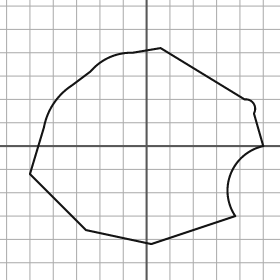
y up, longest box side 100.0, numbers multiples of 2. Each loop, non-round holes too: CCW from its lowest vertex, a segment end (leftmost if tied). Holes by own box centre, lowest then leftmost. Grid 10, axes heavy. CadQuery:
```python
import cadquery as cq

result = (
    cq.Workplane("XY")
    .moveTo(2.0, -42.0)
    .lineTo(38.0, -30.0)
    .threePointArc((36.0, -12.0), (50.0, 0.0))
    .lineTo(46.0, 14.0)
    .threePointArc((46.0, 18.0), (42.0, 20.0))
    .lineTo(6.0, 42.0)
    .lineTo(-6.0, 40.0)
    .threePointArc((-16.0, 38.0), (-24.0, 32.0))
    .lineTo(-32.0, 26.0)
    .threePointArc((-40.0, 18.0), (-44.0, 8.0))
    .lineTo(-50.0, -12.0)
    .lineTo(-26.0, -36.0)
    .close()
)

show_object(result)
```